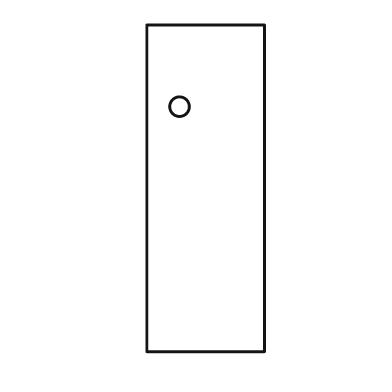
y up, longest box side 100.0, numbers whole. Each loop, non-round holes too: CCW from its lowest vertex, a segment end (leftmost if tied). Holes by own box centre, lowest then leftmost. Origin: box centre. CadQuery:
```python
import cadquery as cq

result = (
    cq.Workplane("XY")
    .moveTo(-18.0, -50.0)
    .lineTo(18.0, -50.0)
    .lineTo(18.0, 50.0)
    .lineTo(-18.0, 50.0)
    .close()
    .moveTo(-8.0, 25.0)
    .circle(3.0)
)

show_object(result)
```